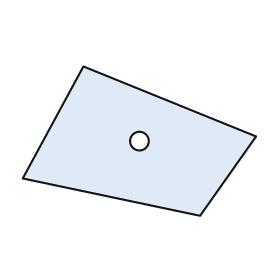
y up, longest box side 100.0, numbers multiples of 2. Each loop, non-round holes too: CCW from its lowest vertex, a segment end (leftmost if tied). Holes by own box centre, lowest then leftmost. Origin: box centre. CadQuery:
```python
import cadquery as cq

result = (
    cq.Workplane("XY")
    .moveTo(26.0, -32.0)
    .lineTo(50.0, 2.0)
    .lineTo(-24.0, 32.0)
    .lineTo(-50.0, -16.0)
    .close()
    .moveTo(0.0, 0.0)
    .circle(4.0)
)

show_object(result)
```